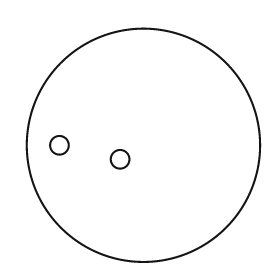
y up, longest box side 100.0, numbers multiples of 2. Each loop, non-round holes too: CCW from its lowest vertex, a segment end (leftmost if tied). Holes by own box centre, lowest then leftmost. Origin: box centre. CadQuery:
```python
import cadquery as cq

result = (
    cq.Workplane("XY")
    .moveTo(0.0, 0.0)
    .circle(50.0)
    .moveTo(-10.0, -6.0)
    .circle(4.0)
    .moveTo(-36.0, 0.0)
    .circle(4.0)
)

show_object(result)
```